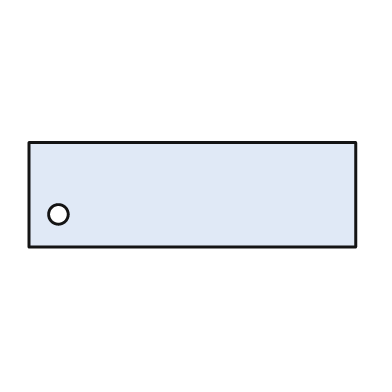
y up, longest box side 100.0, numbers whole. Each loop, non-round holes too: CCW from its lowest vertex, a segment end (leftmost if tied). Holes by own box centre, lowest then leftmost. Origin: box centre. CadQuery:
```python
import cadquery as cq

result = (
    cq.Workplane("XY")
    .moveTo(-50.0, -16.0)
    .lineTo(50.0, -16.0)
    .lineTo(50.0, 16.0)
    .lineTo(-50.0, 16.0)
    .close()
    .moveTo(-41.0, -6.0)
    .circle(3.0)
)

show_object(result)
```